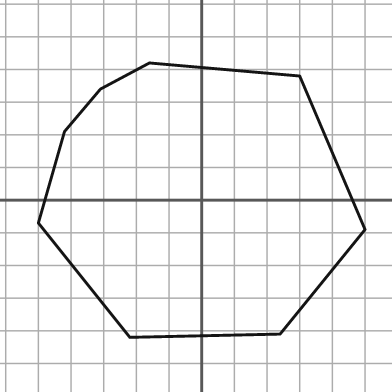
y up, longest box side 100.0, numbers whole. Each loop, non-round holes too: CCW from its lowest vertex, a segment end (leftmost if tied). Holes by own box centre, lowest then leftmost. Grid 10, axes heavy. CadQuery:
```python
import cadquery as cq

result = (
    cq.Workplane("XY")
    .moveTo(-22.0, -42.0)
    .lineTo(24.0, -41.0)
    .lineTo(50.0, -9.0)
    .lineTo(30.0, 38.0)
    .lineTo(-16.0, 42.0)
    .lineTo(-31.0, 34.0)
    .lineTo(-42.0, 21.0)
    .lineTo(-50.0, -7.0)
    .close()
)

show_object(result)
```